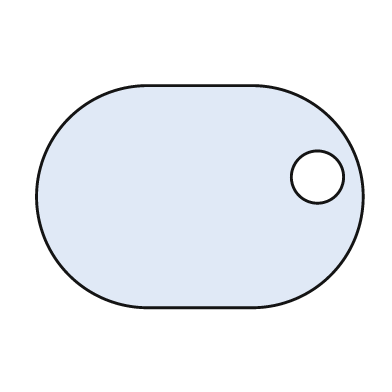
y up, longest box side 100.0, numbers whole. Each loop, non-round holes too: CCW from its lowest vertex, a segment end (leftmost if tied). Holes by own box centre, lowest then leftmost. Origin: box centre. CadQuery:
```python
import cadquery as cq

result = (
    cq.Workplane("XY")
    .moveTo(-16.0, -34.0)
    .lineTo(16.0, -34.0)
    .threePointArc((50.0, 0.0), (16.0, 34.0))
    .lineTo(-16.0, 34.0)
    .threePointArc((-50.0, 0.0), (-16.0, -34.0))
    .close()
    .moveTo(36.0, 6.0)
    .circle(8.0)
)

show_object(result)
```